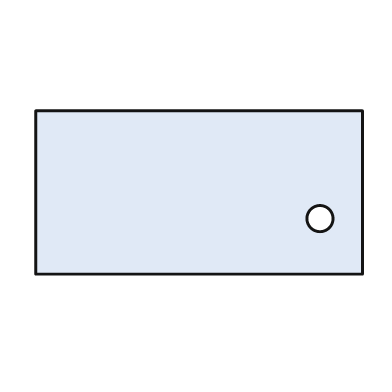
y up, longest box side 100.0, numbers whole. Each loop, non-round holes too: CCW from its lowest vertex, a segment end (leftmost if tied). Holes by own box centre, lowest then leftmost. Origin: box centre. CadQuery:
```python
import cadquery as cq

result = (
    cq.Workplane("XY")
    .moveTo(-50.0, -25.0)
    .lineTo(50.0, -25.0)
    .lineTo(50.0, 25.0)
    .lineTo(-50.0, 25.0)
    .close()
    .moveTo(37.0, -8.0)
    .circle(4.0)
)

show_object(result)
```